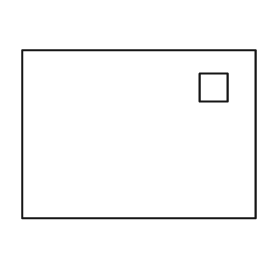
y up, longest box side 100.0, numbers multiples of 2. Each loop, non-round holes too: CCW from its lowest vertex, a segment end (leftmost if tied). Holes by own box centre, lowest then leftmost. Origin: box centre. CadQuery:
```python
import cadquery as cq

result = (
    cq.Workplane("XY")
    .moveTo(-50.0, -36.0)
    .lineTo(50.0, -36.0)
    .lineTo(50.0, 36.0)
    .lineTo(-50.0, 36.0)
    .close()
    .moveTo(26.0, 14.0)
    .lineTo(38.0, 14.0)
    .lineTo(38.0, 26.0)
    .lineTo(26.0, 26.0)
    .close()
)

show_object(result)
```